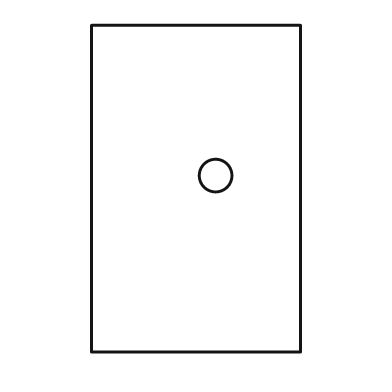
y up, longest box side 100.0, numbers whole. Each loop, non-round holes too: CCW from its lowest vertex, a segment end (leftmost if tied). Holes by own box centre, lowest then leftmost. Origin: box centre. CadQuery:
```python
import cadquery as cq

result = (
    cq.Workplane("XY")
    .moveTo(-32.0, -50.0)
    .lineTo(32.0, -50.0)
    .lineTo(32.0, 50.0)
    .lineTo(-32.0, 50.0)
    .close()
    .moveTo(6.0, 4.0)
    .circle(5.0)
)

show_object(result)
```